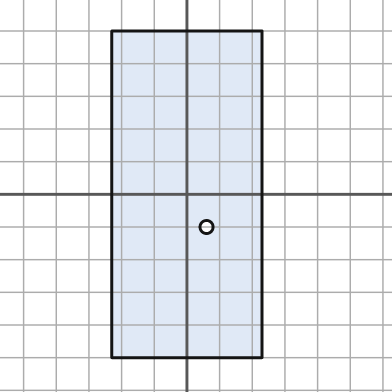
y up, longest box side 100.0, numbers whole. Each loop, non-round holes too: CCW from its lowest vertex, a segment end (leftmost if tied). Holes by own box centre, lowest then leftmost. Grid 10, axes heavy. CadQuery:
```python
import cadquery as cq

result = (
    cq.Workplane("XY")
    .moveTo(-23.0, -50.0)
    .lineTo(23.0, -50.0)
    .lineTo(23.0, 50.0)
    .lineTo(-23.0, 50.0)
    .close()
    .moveTo(6.0, -10.0)
    .circle(2.0)
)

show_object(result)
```